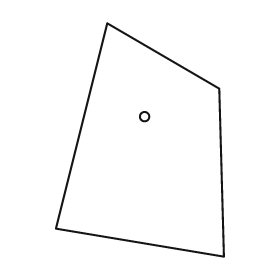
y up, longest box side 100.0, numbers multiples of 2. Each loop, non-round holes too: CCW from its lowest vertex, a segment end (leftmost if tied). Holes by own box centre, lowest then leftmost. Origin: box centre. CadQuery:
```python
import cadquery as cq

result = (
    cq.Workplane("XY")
    .moveTo(36.0, -50.0)
    .lineTo(34.0, 22.0)
    .lineTo(-14.0, 50.0)
    .lineTo(-36.0, -38.0)
    .close()
    .moveTo(2.0, 10.0)
    .circle(2.0)
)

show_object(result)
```